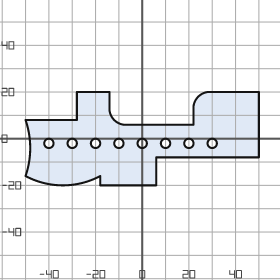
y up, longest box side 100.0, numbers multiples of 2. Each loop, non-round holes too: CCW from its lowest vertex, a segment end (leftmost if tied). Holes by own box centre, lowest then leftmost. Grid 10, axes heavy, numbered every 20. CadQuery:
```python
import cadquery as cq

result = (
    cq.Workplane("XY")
    .moveTo(-18.0, -20.0)
    .lineTo(6.0, -20.0)
    .lineTo(6.0, -8.0)
    .lineTo(50.0, -8.0)
    .lineTo(50.0, 20.0)
    .lineTo(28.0, 20.0)
    .threePointArc((24.0, 18.0), (22.0, 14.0))
    .lineTo(22.0, 6.0)
    .lineTo(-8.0, 6.0)
    .threePointArc((-12.0, 8.0), (-14.0, 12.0))
    .lineTo(-14.0, 20.0)
    .lineTo(-28.0, 20.0)
    .lineTo(-28.0, 8.0)
    .lineTo(-50.0, 8.0)
    .threePointArc((-48.0, -4.0), (-50.0, -16.0))
    .threePointArc((-34.0, -20.0), (-18.0, -16.0))
    .close()
    .moveTo(-40.0, -2.0)
    .circle(2.0)
    .moveTo(-30.0, -2.0)
    .circle(2.0)
    .moveTo(-20.0, -2.0)
    .circle(2.0)
    .moveTo(-10.0, -2.0)
    .circle(2.0)
    .moveTo(0.0, -2.0)
    .circle(2.0)
    .moveTo(10.0, -2.0)
    .circle(2.0)
    .moveTo(20.0, -2.0)
    .circle(2.0)
    .moveTo(30.0, -2.0)
    .circle(2.0)
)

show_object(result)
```